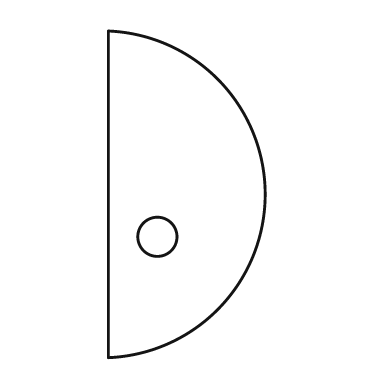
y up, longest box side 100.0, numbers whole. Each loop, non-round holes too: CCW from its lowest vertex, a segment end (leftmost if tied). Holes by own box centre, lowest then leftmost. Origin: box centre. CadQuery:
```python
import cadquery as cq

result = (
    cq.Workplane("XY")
    .moveTo(-24.0, -50.0)
    .threePointArc((24.0, 0.0), (-24.0, 50.0))
    .close()
    .moveTo(-9.0, -13.0)
    .circle(6.0)
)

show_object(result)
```